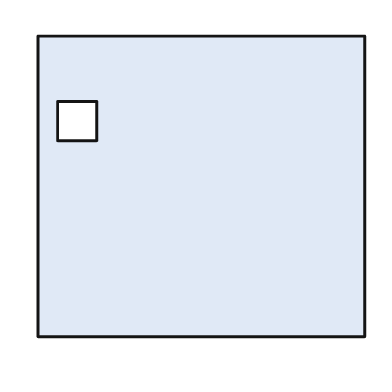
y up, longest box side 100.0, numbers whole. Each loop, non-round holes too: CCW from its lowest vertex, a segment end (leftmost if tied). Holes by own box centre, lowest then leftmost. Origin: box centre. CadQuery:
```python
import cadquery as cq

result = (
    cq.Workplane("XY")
    .moveTo(-50.0, -46.0)
    .lineTo(50.0, -46.0)
    .lineTo(50.0, 46.0)
    .lineTo(-50.0, 46.0)
    .close()
    .moveTo(-44.0, 14.0)
    .lineTo(-32.0, 14.0)
    .lineTo(-32.0, 26.0)
    .lineTo(-44.0, 26.0)
    .close()
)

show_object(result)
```